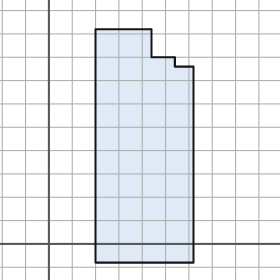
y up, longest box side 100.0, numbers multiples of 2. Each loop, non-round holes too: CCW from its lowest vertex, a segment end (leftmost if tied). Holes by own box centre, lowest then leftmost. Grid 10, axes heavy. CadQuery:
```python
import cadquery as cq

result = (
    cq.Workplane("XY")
    .moveTo(20.0, -8.0)
    .lineTo(62.0, -8.0)
    .lineTo(62.0, 76.0)
    .lineTo(54.0, 76.0)
    .lineTo(54.0, 80.0)
    .lineTo(44.0, 80.0)
    .lineTo(44.0, 92.0)
    .lineTo(20.0, 92.0)
    .close()
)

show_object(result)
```